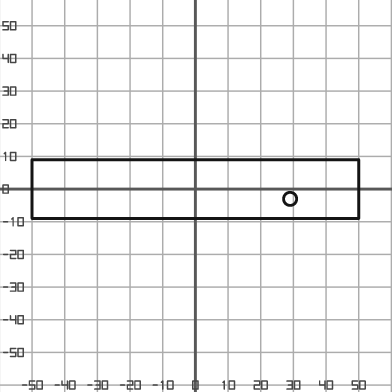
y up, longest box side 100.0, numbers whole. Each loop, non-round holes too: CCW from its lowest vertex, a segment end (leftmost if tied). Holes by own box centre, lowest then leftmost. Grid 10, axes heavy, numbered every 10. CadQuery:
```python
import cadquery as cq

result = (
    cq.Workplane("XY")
    .moveTo(-50.0, -9.0)
    .lineTo(50.0, -9.0)
    .lineTo(50.0, 9.0)
    .lineTo(-50.0, 9.0)
    .close()
    .moveTo(29.0, -3.0)
    .circle(2.0)
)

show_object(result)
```